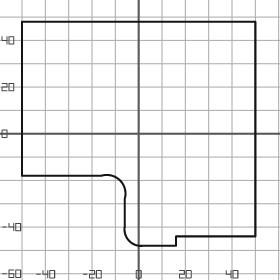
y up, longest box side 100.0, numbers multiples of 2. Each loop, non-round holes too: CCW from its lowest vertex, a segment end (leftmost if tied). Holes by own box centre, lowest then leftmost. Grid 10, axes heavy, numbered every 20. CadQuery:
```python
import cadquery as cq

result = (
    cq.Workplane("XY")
    .moveTo(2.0, -48.0)
    .lineTo(16.0, -48.0)
    .lineTo(16.0, -44.0)
    .lineTo(50.0, -44.0)
    .lineTo(50.0, 48.0)
    .lineTo(-50.0, 48.0)
    .lineTo(-50.0, -18.0)
    .lineTo(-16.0, -18.0)
    .threePointArc((-8.0, -20.0), (-6.0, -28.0))
    .lineTo(-6.0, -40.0)
    .threePointArc((-4.0, -46.0), (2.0, -48.0))
    .close()
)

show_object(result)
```